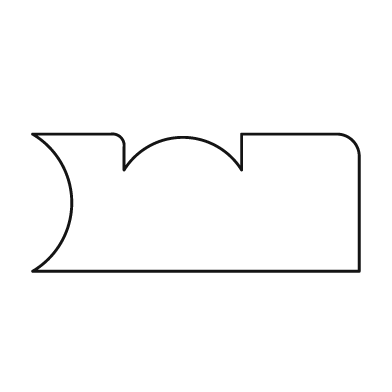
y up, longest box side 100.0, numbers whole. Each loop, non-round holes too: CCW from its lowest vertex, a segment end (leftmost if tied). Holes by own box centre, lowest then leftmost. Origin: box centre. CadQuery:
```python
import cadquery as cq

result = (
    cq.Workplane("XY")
    .moveTo(-50.0, -21.0)
    .lineTo(50.0, -21.0)
    .lineTo(50.0, 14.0)
    .threePointArc((48.0, 19.0), (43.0, 21.0))
    .lineTo(14.0, 21.0)
    .lineTo(14.0, 10.0)
    .threePointArc((-4.0, 20.0), (-22.0, 10.0))
    .lineTo(-22.0, 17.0)
    .threePointArc((-23.0, 20.0), (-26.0, 21.0))
    .lineTo(-50.0, 21.0)
    .threePointArc((-38.0, 0.0), (-50.0, -21.0))
    .close()
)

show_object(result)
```